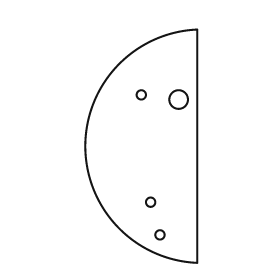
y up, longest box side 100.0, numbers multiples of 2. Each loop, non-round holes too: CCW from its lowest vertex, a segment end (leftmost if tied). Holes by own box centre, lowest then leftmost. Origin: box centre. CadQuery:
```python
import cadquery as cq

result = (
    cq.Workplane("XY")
    .moveTo(24.0, -50.0)
    .lineTo(24.0, 50.0)
    .threePointArc((-24.0, 0.0), (24.0, -50.0))
    .close()
    .moveTo(8.0, -38.0)
    .circle(2.0)
    .moveTo(4.0, -24.0)
    .circle(2.0)
    .moveTo(16.0, 20.0)
    .circle(4.0)
    .moveTo(0.0, 22.0)
    .circle(2.0)
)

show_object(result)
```